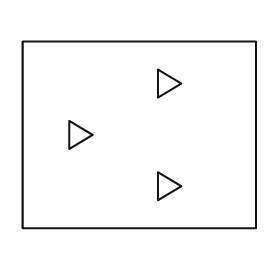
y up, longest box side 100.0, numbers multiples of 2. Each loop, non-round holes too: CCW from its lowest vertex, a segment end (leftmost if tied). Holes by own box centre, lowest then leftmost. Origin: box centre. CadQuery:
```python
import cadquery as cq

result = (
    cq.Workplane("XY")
    .moveTo(-50.0, -40.0)
    .lineTo(50.0, -40.0)
    .lineTo(50.0, 40.0)
    .lineTo(-50.0, 40.0)
    .close()
    .moveTo(8.0, -28.0)
    .lineTo(18.0, -22.0)
    .lineTo(8.0, -16.0)
    .close()
    .moveTo(-30.0, -6.0)
    .lineTo(-20.0, 0.0)
    .lineTo(-30.0, 6.0)
    .close()
    .moveTo(8.0, 16.0)
    .lineTo(18.0, 22.0)
    .lineTo(8.0, 28.0)
    .close()
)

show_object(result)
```